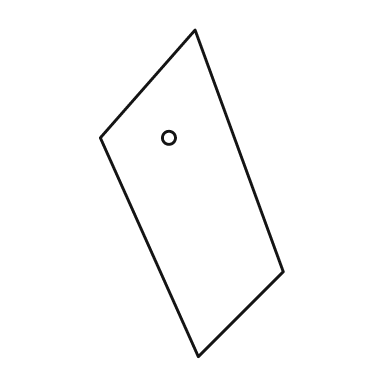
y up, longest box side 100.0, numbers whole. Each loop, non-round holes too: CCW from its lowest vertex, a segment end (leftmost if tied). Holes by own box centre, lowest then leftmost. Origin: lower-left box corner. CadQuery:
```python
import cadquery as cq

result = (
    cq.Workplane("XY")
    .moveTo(30.0, 0.0)
    .lineTo(56.0, 26.0)
    .lineTo(29.0, 100.0)
    .lineTo(0.0, 67.0)
    .close()
    .moveTo(21.0, 67.0)
    .circle(2.0)
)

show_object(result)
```